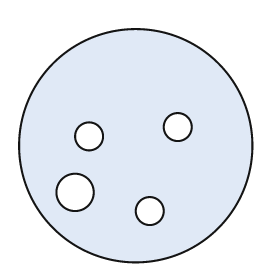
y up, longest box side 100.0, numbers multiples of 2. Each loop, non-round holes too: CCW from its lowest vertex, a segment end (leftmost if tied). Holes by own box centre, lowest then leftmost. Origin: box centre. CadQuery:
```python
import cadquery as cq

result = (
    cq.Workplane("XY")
    .moveTo(0.0, 0.0)
    .circle(50.0)
    .moveTo(6.0, -28.0)
    .circle(6.0)
    .moveTo(-26.0, -20.0)
    .circle(8.0)
    .moveTo(-20.0, 4.0)
    .circle(6.0)
    .moveTo(18.0, 8.0)
    .circle(6.0)
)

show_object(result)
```